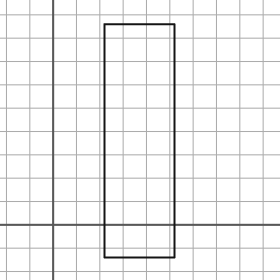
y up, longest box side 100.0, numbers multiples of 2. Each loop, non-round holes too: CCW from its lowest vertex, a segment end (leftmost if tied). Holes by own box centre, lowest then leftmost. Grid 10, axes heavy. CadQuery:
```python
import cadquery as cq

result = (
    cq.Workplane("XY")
    .moveTo(22.0, -14.0)
    .lineTo(52.0, -14.0)
    .lineTo(52.0, 86.0)
    .lineTo(22.0, 86.0)
    .close()
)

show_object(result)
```